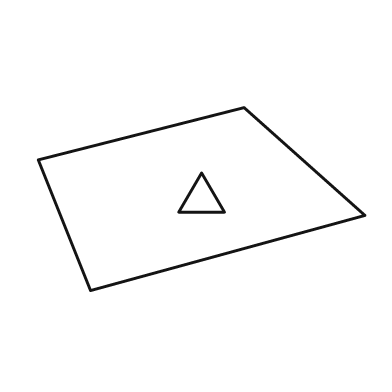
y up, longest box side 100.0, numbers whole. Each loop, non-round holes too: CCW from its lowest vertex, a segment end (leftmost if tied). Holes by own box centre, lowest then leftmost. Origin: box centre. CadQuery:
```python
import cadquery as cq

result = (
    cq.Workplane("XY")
    .moveTo(-34.0, -28.0)
    .lineTo(50.0, -5.0)
    .lineTo(13.0, 28.0)
    .lineTo(-50.0, 12.0)
    .close()
    .moveTo(-7.0, -4.0)
    .lineTo(7.0, -4.0)
    .lineTo(0.0, 8.0)
    .close()
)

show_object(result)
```